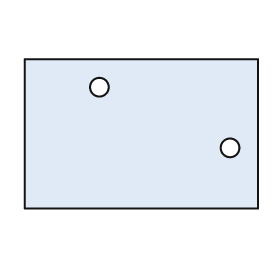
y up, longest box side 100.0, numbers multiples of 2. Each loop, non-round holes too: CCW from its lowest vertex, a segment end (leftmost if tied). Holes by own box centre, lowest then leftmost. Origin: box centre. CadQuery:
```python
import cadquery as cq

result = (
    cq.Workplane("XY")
    .moveTo(-50.0, -32.0)
    .lineTo(50.0, -32.0)
    .lineTo(50.0, 32.0)
    .lineTo(-50.0, 32.0)
    .close()
    .moveTo(38.0, -6.0)
    .circle(4.0)
    .moveTo(-18.0, 20.0)
    .circle(4.0)
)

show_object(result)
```